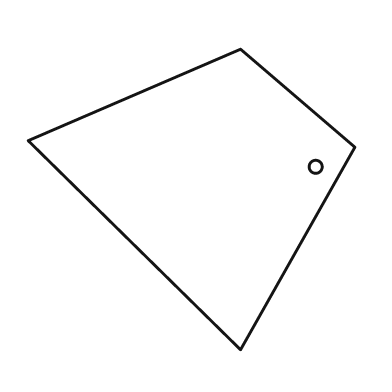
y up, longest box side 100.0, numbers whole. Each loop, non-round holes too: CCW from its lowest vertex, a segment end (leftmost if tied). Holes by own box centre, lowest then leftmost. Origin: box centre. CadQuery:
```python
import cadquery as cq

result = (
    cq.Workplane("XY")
    .moveTo(15.0, -46.0)
    .lineTo(50.0, 16.0)
    .lineTo(15.0, 46.0)
    .lineTo(-50.0, 18.0)
    .close()
    .moveTo(38.0, 10.0)
    .circle(2.0)
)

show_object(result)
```